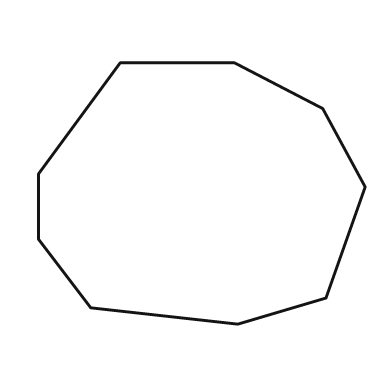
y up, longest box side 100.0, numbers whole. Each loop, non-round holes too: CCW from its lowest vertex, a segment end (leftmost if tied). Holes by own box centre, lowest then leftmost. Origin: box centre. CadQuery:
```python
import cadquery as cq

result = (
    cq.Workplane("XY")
    .moveTo(11.0, -40.0)
    .lineTo(38.0, -32.0)
    .lineTo(50.0, 2.0)
    .lineTo(37.0, 26.0)
    .lineTo(10.0, 40.0)
    .lineTo(-25.0, 40.0)
    .lineTo(-50.0, 6.0)
    .lineTo(-50.0, -14.0)
    .lineTo(-34.0, -35.0)
    .close()
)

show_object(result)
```